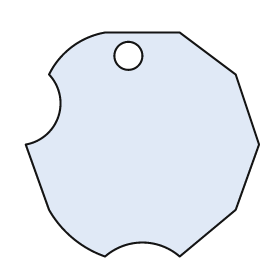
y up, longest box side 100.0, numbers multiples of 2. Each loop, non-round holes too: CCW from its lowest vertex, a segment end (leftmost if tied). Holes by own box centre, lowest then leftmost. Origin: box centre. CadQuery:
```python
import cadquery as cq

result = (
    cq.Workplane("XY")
    .moveTo(-16.0, -48.0)
    .threePointArc((0.0, -42.0), (16.0, -48.0))
    .lineTo(40.0, -28.0)
    .lineTo(50.0, 0.0)
    .lineTo(40.0, 30.0)
    .lineTo(16.0, 48.0)
    .lineTo(-16.0, 48.0)
    .threePointArc((-30.0, 42.0), (-40.0, 30.0))
    .threePointArc((-36.0, 12.0), (-50.0, 0.0))
    .lineTo(-40.0, -28.0)
    .threePointArc((-30.0, -40.0), (-16.0, -48.0))
    .close()
    .moveTo(-6.0, 38.0)
    .circle(6.0)
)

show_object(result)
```